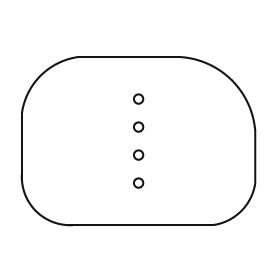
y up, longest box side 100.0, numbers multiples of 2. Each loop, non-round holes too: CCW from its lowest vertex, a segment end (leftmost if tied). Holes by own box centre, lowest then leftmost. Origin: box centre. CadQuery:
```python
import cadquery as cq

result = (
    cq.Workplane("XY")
    .moveTo(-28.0, -36.0)
    .lineTo(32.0, -36.0)
    .threePointArc((44.0, -30.0), (50.0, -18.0))
    .lineTo(50.0, 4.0)
    .threePointArc((40.0, 26.0), (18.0, 36.0))
    .lineTo(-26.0, 36.0)
    .threePointArc((-42.0, 28.0), (-50.0, 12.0))
    .lineTo(-50.0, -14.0)
    .threePointArc((-44.0, -30.0), (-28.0, -36.0))
    .close()
    .moveTo(0.0, -18.0)
    .circle(2.0)
    .moveTo(0.0, -6.0)
    .circle(2.0)
    .moveTo(0.0, 6.0)
    .circle(2.0)
    .moveTo(0.0, 18.0)
    .circle(2.0)
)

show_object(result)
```